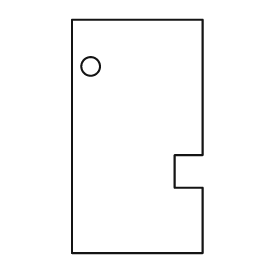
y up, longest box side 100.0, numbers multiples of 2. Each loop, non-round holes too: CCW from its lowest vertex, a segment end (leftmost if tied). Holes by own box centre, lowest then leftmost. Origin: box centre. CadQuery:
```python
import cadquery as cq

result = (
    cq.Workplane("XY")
    .moveTo(-28.0, -50.0)
    .lineTo(28.0, -50.0)
    .lineTo(28.0, -22.0)
    .lineTo(16.0, -22.0)
    .lineTo(16.0, -8.0)
    .lineTo(28.0, -8.0)
    .lineTo(28.0, 50.0)
    .lineTo(-28.0, 50.0)
    .close()
    .moveTo(-20.0, 30.0)
    .circle(4.0)
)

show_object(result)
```